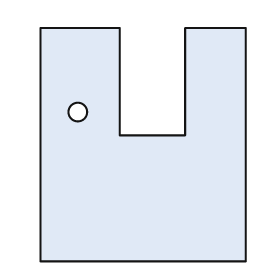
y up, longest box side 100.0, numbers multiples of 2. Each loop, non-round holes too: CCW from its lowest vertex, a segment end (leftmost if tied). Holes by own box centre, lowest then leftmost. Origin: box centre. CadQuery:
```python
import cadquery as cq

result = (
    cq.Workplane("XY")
    .moveTo(-44.0, -50.0)
    .lineTo(44.0, -50.0)
    .lineTo(44.0, 50.0)
    .lineTo(18.0, 50.0)
    .lineTo(18.0, 4.0)
    .lineTo(-10.0, 4.0)
    .lineTo(-10.0, 50.0)
    .lineTo(-44.0, 50.0)
    .close()
    .moveTo(-28.0, 14.0)
    .circle(4.0)
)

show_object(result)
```